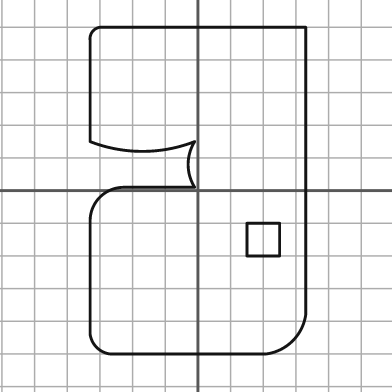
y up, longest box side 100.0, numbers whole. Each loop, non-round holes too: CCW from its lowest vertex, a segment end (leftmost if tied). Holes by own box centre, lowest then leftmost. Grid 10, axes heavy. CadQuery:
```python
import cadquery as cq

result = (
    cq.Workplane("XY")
    .moveTo(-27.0, -50.0)
    .lineTo(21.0, -50.0)
    .threePointArc((29.0, -46.0), (33.0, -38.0))
    .lineTo(33.0, 50.0)
    .lineTo(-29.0, 50.0)
    .threePointArc((-32.0, 49.0), (-33.0, 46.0))
    .lineTo(-33.0, 15.0)
    .threePointArc((-17.0, 12.0), (-1.0, 15.0))
    .threePointArc((-3.0, 8.0), (-1.0, 1.0))
    .lineTo(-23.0, 1.0)
    .threePointArc((-30.0, -2.0), (-33.0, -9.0))
    .lineTo(-33.0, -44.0)
    .threePointArc((-31.0, -48.0), (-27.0, -50.0))
    .close()
    .moveTo(15.0, -20.0)
    .lineTo(25.0, -20.0)
    .lineTo(25.0, -10.0)
    .lineTo(15.0, -10.0)
    .close()
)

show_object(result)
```